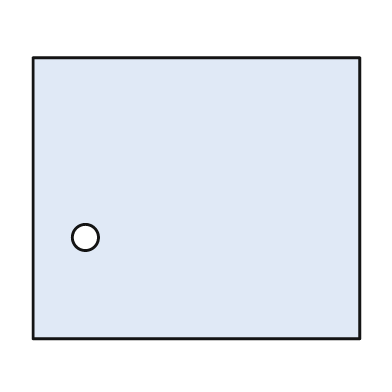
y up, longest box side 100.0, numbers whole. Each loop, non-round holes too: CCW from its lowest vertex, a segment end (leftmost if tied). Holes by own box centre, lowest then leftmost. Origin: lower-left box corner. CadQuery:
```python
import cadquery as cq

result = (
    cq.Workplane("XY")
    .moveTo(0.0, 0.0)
    .lineTo(100.0, 0.0)
    .lineTo(100.0, 86.0)
    .lineTo(0.0, 86.0)
    .close()
    .moveTo(16.0, 31.0)
    .circle(4.0)
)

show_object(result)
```